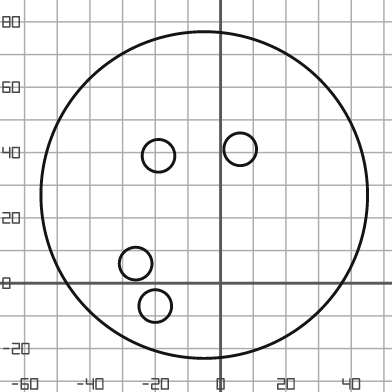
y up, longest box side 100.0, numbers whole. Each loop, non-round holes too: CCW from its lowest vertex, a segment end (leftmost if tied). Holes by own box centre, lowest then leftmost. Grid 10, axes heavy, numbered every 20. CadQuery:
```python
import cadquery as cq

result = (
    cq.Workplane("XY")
    .moveTo(-5.0, 27.0)
    .circle(50.0)
    .moveTo(-20.0, -7.0)
    .circle(5.0)
    .moveTo(-26.0, 6.0)
    .circle(5.0)
    .moveTo(-19.0, 39.0)
    .circle(5.0)
    .moveTo(6.0, 41.0)
    .circle(5.0)
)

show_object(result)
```